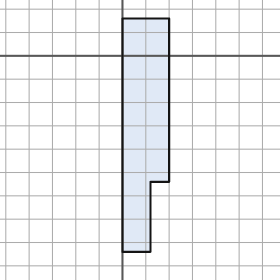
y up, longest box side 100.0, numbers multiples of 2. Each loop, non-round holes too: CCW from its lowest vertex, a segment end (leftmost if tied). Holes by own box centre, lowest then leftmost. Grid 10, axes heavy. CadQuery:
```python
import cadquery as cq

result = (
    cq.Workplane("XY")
    .moveTo(0.0, -84.0)
    .lineTo(12.0, -84.0)
    .lineTo(12.0, -54.0)
    .lineTo(20.0, -54.0)
    .lineTo(20.0, 16.0)
    .lineTo(0.0, 16.0)
    .close()
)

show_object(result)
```